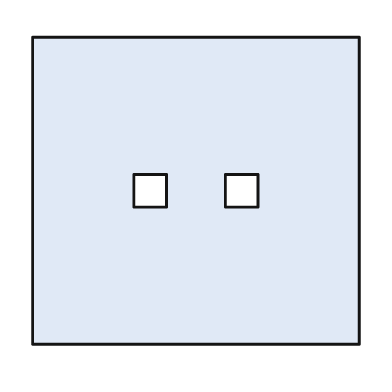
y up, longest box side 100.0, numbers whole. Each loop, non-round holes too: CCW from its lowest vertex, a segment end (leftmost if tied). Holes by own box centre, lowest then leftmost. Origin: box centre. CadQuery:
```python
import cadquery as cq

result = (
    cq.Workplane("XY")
    .moveTo(-50.0, -47.0)
    .lineTo(50.0, -47.0)
    .lineTo(50.0, 47.0)
    .lineTo(-50.0, 47.0)
    .close()
    .moveTo(-19.0, -5.0)
    .lineTo(-9.0, -5.0)
    .lineTo(-9.0, 5.0)
    .lineTo(-19.0, 5.0)
    .close()
    .moveTo(9.0, -5.0)
    .lineTo(19.0, -5.0)
    .lineTo(19.0, 5.0)
    .lineTo(9.0, 5.0)
    .close()
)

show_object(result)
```